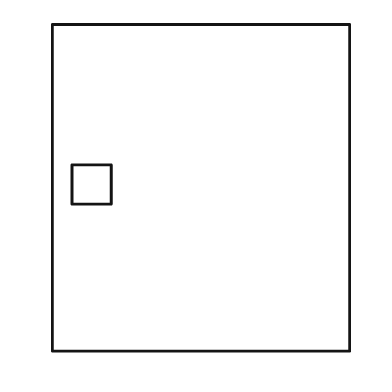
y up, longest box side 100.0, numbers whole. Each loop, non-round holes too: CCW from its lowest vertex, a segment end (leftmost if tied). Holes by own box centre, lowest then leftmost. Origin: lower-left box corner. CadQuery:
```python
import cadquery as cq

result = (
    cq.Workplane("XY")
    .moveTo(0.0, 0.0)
    .lineTo(91.0, 0.0)
    .lineTo(91.0, 100.0)
    .lineTo(0.0, 100.0)
    .close()
    .moveTo(6.0, 45.0)
    .lineTo(18.0, 45.0)
    .lineTo(18.0, 57.0)
    .lineTo(6.0, 57.0)
    .close()
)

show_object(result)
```